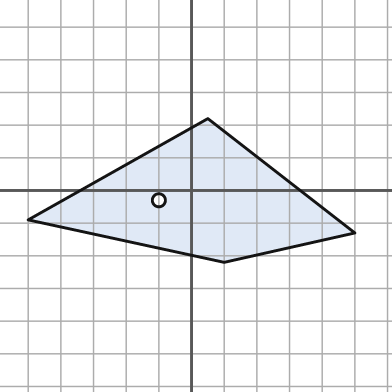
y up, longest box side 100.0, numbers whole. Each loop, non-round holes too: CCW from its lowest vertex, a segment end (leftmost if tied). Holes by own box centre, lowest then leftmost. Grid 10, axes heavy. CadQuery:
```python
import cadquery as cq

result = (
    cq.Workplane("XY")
    .moveTo(10.0, -22.0)
    .lineTo(50.0, -13.0)
    .lineTo(5.0, 22.0)
    .lineTo(-50.0, -9.0)
    .close()
    .moveTo(-10.0, -3.0)
    .circle(2.0)
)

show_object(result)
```